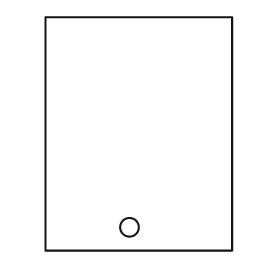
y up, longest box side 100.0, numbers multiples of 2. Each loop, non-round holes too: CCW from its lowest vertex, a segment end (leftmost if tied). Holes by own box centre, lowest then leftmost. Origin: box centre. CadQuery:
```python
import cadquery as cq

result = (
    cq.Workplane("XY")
    .moveTo(-40.0, -50.0)
    .lineTo(40.0, -50.0)
    .lineTo(40.0, 50.0)
    .lineTo(-40.0, 50.0)
    .close()
    .moveTo(-4.0, -40.0)
    .circle(4.0)
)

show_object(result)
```